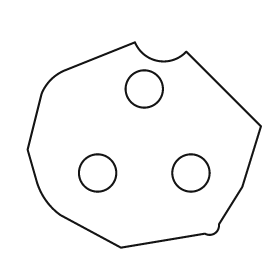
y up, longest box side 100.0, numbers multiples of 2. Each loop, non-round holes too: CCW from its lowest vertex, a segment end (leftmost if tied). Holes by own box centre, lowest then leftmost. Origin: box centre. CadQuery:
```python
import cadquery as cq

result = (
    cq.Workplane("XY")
    .moveTo(-10.0, -44.0)
    .lineTo(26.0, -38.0)
    .threePointArc((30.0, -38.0), (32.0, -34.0))
    .lineTo(42.0, -18.0)
    .lineTo(50.0, 8.0)
    .lineTo(18.0, 40.0)
    .threePointArc((6.0, 36.0), (-4.0, 44.0))
    .lineTo(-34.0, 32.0)
    .threePointArc((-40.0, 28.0), (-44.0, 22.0))
    .lineTo(-50.0, -2.0)
    .lineTo(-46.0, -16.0)
    .threePointArc((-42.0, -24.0), (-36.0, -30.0))
    .close()
    .moveTo(-20.0, -12.0)
    .circle(8.0)
    .moveTo(20.0, -12.0)
    .circle(8.0)
    .moveTo(0.0, 24.0)
    .circle(8.0)
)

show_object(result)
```